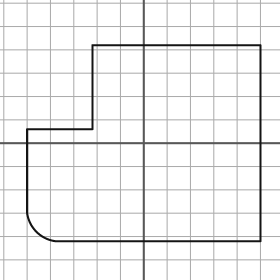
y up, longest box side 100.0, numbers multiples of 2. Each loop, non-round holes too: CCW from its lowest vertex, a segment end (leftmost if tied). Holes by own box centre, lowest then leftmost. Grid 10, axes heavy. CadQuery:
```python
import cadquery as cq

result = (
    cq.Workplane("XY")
    .moveTo(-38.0, -42.0)
    .lineTo(50.0, -42.0)
    .lineTo(50.0, 42.0)
    .lineTo(-22.0, 42.0)
    .lineTo(-22.0, 6.0)
    .lineTo(-50.0, 6.0)
    .lineTo(-50.0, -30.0)
    .threePointArc((-46.0, -38.0), (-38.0, -42.0))
    .close()
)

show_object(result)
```